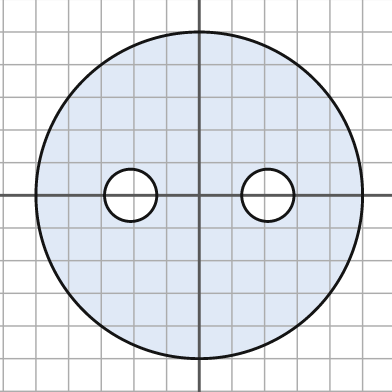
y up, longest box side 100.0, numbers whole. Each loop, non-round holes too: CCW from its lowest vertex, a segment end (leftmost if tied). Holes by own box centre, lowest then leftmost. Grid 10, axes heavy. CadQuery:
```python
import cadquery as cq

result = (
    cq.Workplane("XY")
    .moveTo(0.0, 0.0)
    .circle(50.0)
    .moveTo(-21.0, 0.0)
    .circle(8.0)
    .moveTo(21.0, 0.0)
    .circle(8.0)
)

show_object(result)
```